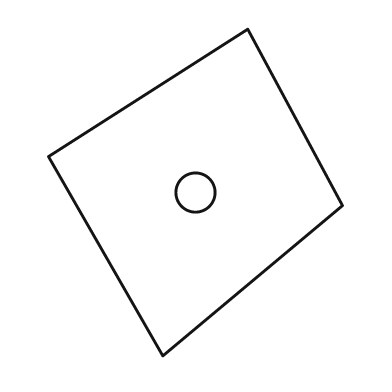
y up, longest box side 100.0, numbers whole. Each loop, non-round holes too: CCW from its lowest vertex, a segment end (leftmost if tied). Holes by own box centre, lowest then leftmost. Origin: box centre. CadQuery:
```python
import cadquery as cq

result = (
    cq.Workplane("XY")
    .moveTo(-10.0, -50.0)
    .lineTo(45.0, -4.0)
    .lineTo(16.0, 50.0)
    .lineTo(-45.0, 11.0)
    .close()
    .moveTo(0.0, 0.0)
    .circle(6.0)
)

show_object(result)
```